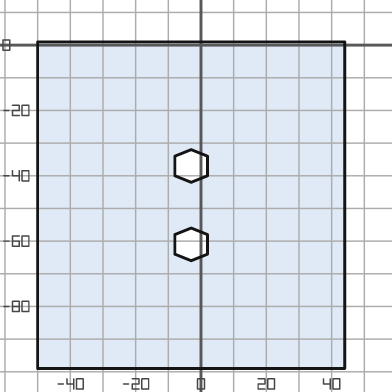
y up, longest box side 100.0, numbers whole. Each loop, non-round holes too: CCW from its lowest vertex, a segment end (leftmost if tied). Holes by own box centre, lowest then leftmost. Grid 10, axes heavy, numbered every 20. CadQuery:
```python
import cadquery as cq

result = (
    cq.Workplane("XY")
    .moveTo(-50.0, -99.0)
    .lineTo(44.0, -99.0)
    .lineTo(44.0, 1.0)
    .lineTo(-50.0, 1.0)
    .close()
    .moveTo(-3.0, -66.0)
    .lineTo(2.0, -64.0)
    .lineTo(2.0, -58.0)
    .lineTo(-3.0, -56.0)
    .lineTo(-8.0, -58.0)
    .lineTo(-8.0, -64.0)
    .close()
    .moveTo(-3.0, -42.0)
    .lineTo(2.0, -40.0)
    .lineTo(2.0, -34.0)
    .lineTo(-3.0, -32.0)
    .lineTo(-8.0, -34.0)
    .lineTo(-8.0, -40.0)
    .close()
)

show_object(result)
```